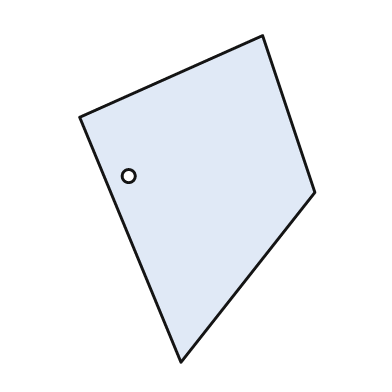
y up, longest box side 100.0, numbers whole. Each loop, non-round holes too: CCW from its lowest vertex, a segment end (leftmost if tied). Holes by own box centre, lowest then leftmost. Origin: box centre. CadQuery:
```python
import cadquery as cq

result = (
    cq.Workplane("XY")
    .moveTo(-5.0, -50.0)
    .lineTo(36.0, 2.0)
    .lineTo(20.0, 50.0)
    .lineTo(-36.0, 25.0)
    .close()
    .moveTo(-21.0, 7.0)
    .circle(2.0)
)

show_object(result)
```